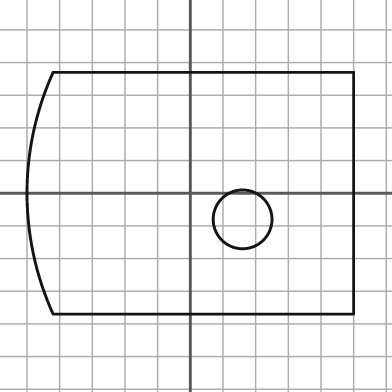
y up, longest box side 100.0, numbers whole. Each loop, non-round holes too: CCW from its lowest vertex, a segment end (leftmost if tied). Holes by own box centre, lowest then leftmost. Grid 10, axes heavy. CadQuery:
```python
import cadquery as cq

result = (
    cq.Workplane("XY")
    .moveTo(-42.0, -37.0)
    .lineTo(50.0, -37.0)
    .lineTo(50.0, 37.0)
    .lineTo(-42.0, 37.0)
    .threePointArc((-50.0, 0.0), (-42.0, -37.0))
    .close()
    .moveTo(16.0, -8.0)
    .circle(9.0)
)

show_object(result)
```